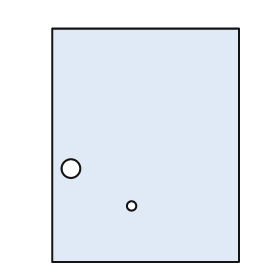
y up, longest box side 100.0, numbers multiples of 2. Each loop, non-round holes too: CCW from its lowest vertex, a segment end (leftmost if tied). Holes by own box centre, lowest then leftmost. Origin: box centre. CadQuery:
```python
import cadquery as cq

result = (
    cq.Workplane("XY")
    .moveTo(-40.0, -50.0)
    .lineTo(40.0, -50.0)
    .lineTo(40.0, 50.0)
    .lineTo(-40.0, 50.0)
    .close()
    .moveTo(-6.0, -26.0)
    .circle(2.0)
    .moveTo(-32.0, -10.0)
    .circle(4.0)
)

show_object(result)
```